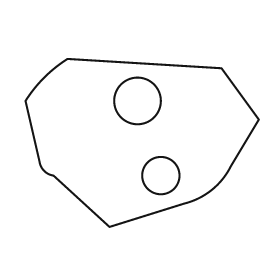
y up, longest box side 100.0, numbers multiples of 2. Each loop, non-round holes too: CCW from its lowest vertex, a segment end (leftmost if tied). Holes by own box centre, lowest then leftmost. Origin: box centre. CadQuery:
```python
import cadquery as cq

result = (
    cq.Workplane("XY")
    .moveTo(-14.0, -36.0)
    .lineTo(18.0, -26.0)
    .threePointArc((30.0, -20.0), (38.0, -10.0))
    .lineTo(50.0, 10.0)
    .lineTo(34.0, 32.0)
    .lineTo(-32.0, 36.0)
    .threePointArc((-42.0, 28.0), (-50.0, 18.0))
    .lineTo(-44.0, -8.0)
    .threePointArc((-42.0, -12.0), (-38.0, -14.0))
    .close()
    .moveTo(8.0, -14.0)
    .circle(8.0)
    .moveTo(-2.0, 18.0)
    .circle(10.0)
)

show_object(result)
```